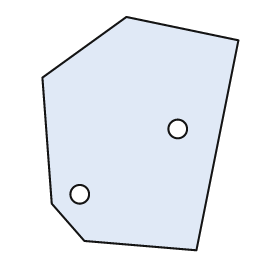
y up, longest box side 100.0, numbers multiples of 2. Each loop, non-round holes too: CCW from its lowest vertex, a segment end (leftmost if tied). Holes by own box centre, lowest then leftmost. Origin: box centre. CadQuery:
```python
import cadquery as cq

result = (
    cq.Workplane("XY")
    .moveTo(24.0, -50.0)
    .lineTo(42.0, 40.0)
    .lineTo(-6.0, 50.0)
    .lineTo(-42.0, 24.0)
    .lineTo(-38.0, -30.0)
    .lineTo(-24.0, -46.0)
    .close()
    .moveTo(-26.0, -26.0)
    .circle(4.0)
    .moveTo(16.0, 2.0)
    .circle(4.0)
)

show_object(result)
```